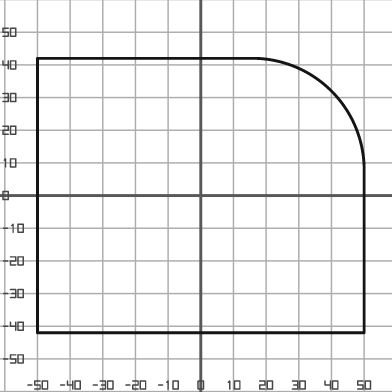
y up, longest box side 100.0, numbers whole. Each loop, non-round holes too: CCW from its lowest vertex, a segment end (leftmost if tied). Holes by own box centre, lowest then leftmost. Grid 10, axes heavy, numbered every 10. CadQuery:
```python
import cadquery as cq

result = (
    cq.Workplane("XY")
    .moveTo(-50.0, -42.0)
    .lineTo(50.0, -42.0)
    .lineTo(50.0, 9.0)
    .threePointArc((40.0, 32.0), (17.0, 42.0))
    .lineTo(-50.0, 42.0)
    .close()
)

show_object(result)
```